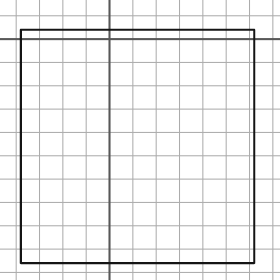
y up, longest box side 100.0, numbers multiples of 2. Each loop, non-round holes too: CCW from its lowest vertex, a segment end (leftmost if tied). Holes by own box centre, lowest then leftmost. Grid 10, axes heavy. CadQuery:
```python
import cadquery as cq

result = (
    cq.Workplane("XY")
    .moveTo(-38.0, -96.0)
    .lineTo(62.0, -96.0)
    .lineTo(62.0, 4.0)
    .lineTo(-38.0, 4.0)
    .close()
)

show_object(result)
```